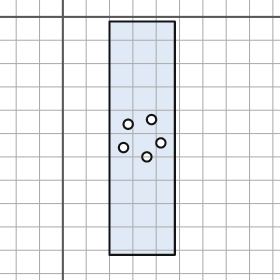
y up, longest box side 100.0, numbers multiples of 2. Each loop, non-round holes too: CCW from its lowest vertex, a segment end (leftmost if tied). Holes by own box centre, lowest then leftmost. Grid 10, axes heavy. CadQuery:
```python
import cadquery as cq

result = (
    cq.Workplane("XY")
    .moveTo(20.0, -102.0)
    .lineTo(48.0, -102.0)
    .lineTo(48.0, -2.0)
    .lineTo(20.0, -2.0)
    .close()
    .moveTo(36.0, -60.0)
    .circle(2.0)
    .moveTo(26.0, -56.0)
    .circle(2.0)
    .moveTo(42.0, -54.0)
    .circle(2.0)
    .moveTo(28.0, -46.0)
    .circle(2.0)
    .moveTo(38.0, -44.0)
    .circle(2.0)
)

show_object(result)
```